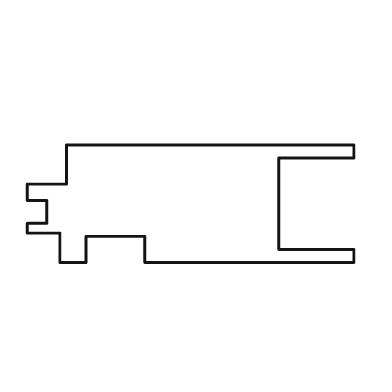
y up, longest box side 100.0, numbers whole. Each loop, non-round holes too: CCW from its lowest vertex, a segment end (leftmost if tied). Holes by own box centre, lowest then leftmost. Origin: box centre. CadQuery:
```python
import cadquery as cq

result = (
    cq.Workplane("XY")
    .moveTo(-40.0, -18.0)
    .lineTo(-32.0, -18.0)
    .lineTo(-32.0, -10.0)
    .lineTo(-14.0, -10.0)
    .lineTo(-14.0, -18.0)
    .lineTo(50.0, -18.0)
    .lineTo(50.0, -14.0)
    .lineTo(27.0, -14.0)
    .lineTo(27.0, 14.0)
    .lineTo(50.0, 14.0)
    .lineTo(50.0, 18.0)
    .lineTo(-38.0, 18.0)
    .lineTo(-38.0, 6.0)
    .lineTo(-50.0, 6.0)
    .lineTo(-50.0, 1.0)
    .lineTo(-44.0, 1.0)
    .lineTo(-44.0, -6.0)
    .lineTo(-50.0, -6.0)
    .lineTo(-50.0, -9.0)
    .lineTo(-40.0, -9.0)
    .close()
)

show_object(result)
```